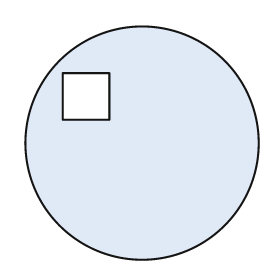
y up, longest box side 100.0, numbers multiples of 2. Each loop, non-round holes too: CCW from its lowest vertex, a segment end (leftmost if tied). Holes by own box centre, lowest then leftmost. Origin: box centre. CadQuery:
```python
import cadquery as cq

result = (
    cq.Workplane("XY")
    .moveTo(0.0, 0.0)
    .circle(50.0)
    .moveTo(-34.0, 10.0)
    .lineTo(-14.0, 10.0)
    .lineTo(-14.0, 30.0)
    .lineTo(-34.0, 30.0)
    .close()
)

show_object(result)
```